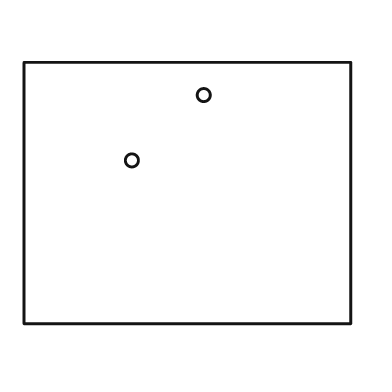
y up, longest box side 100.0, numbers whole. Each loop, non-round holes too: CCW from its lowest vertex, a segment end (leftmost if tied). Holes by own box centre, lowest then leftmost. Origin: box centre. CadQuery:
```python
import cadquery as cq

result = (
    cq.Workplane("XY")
    .moveTo(-50.0, -40.0)
    .lineTo(50.0, -40.0)
    .lineTo(50.0, 40.0)
    .lineTo(-50.0, 40.0)
    .close()
    .moveTo(-17.0, 10.0)
    .circle(2.0)
    .moveTo(5.0, 30.0)
    .circle(2.0)
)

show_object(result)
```